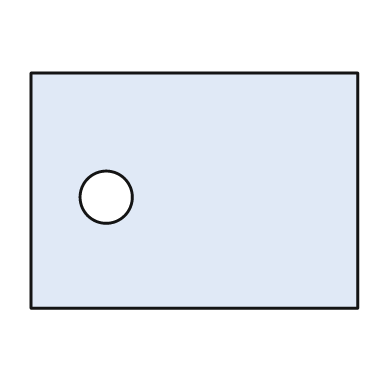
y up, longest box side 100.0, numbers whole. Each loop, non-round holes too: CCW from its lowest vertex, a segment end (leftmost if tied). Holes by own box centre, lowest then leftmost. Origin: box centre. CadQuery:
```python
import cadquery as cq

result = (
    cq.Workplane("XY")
    .moveTo(-50.0, -36.0)
    .lineTo(50.0, -36.0)
    .lineTo(50.0, 36.0)
    .lineTo(-50.0, 36.0)
    .close()
    .moveTo(-27.0, -2.0)
    .circle(8.0)
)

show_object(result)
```